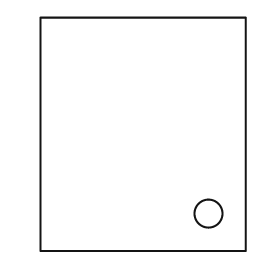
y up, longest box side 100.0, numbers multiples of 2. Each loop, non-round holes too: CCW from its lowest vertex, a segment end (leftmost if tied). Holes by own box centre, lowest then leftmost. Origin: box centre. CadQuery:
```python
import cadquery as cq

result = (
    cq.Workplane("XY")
    .moveTo(-44.0, -50.0)
    .lineTo(44.0, -50.0)
    .lineTo(44.0, 50.0)
    .lineTo(-44.0, 50.0)
    .close()
    .moveTo(28.0, -34.0)
    .circle(6.0)
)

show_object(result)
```